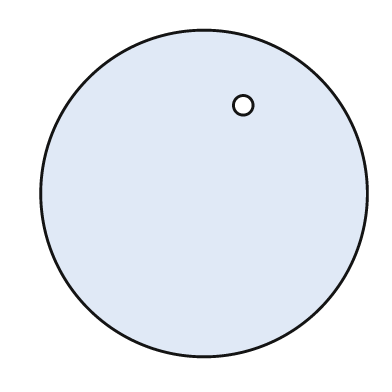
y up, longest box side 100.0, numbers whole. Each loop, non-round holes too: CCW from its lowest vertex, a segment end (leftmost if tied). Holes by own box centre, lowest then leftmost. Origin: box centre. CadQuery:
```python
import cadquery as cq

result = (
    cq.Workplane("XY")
    .moveTo(0.0, 0.0)
    .circle(50.0)
    .moveTo(12.0, 27.0)
    .circle(3.0)
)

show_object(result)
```